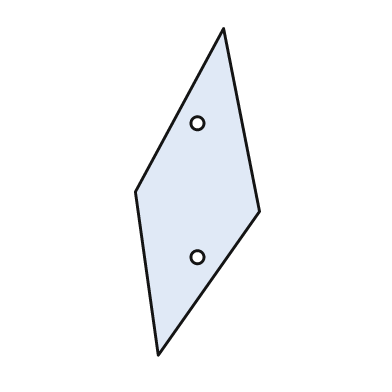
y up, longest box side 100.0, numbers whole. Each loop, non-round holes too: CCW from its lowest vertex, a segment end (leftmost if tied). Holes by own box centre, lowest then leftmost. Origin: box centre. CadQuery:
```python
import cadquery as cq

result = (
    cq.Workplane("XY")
    .moveTo(-12.0, -50.0)
    .lineTo(19.0, -6.0)
    .lineTo(8.0, 50.0)
    .lineTo(-19.0, 0.0)
    .close()
    .moveTo(0.0, -20.0)
    .circle(2.0)
    .moveTo(0.0, 21.0)
    .circle(2.0)
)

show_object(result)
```